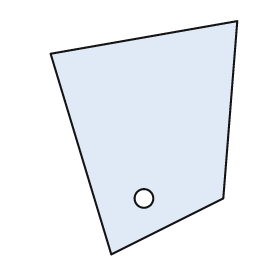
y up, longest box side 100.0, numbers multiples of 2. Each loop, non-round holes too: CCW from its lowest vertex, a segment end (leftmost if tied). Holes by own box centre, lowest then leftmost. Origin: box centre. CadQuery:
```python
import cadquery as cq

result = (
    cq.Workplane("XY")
    .moveTo(-14.0, -50.0)
    .lineTo(34.0, -26.0)
    .lineTo(40.0, 50.0)
    .lineTo(-40.0, 36.0)
    .close()
    .moveTo(0.0, -26.0)
    .circle(4.0)
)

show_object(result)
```